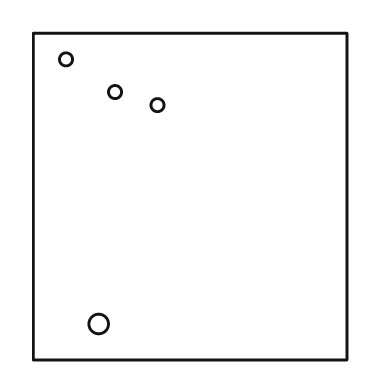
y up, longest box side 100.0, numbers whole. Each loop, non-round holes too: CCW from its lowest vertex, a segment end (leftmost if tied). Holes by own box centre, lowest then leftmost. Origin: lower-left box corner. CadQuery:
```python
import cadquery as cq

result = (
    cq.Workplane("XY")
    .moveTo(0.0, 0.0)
    .lineTo(96.0, 0.0)
    .lineTo(96.0, 100.0)
    .lineTo(0.0, 100.0)
    .close()
    .moveTo(20.0, 11.0)
    .circle(3.0)
    .moveTo(38.0, 78.0)
    .circle(2.0)
    .moveTo(25.0, 82.0)
    .circle(2.0)
    .moveTo(10.0, 92.0)
    .circle(2.0)
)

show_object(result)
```